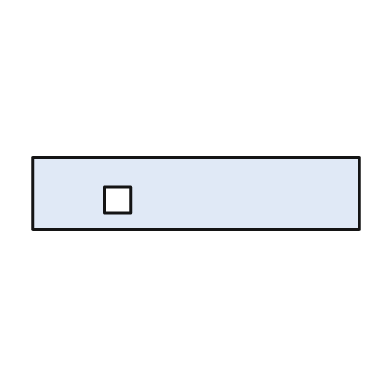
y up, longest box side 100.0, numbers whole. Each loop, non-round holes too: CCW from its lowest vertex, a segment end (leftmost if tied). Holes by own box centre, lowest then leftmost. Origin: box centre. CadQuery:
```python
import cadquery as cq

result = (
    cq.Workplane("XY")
    .moveTo(-50.0, -11.0)
    .lineTo(50.0, -11.0)
    .lineTo(50.0, 11.0)
    .lineTo(-50.0, 11.0)
    .close()
    .moveTo(-28.0, -6.0)
    .lineTo(-20.0, -6.0)
    .lineTo(-20.0, 2.0)
    .lineTo(-28.0, 2.0)
    .close()
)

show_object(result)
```